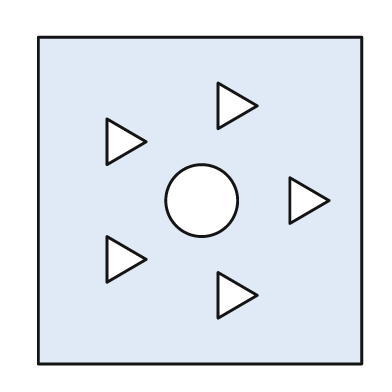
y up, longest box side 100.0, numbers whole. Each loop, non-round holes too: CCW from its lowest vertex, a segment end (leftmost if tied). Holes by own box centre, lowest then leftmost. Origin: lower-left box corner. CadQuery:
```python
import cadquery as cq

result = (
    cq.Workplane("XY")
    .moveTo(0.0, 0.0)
    .lineTo(99.0, 0.0)
    .lineTo(99.0, 100.0)
    .lineTo(0.0, 100.0)
    .close()
    .moveTo(55.0, 14.0)
    .lineTo(67.0, 21.0)
    .lineTo(55.0, 28.0)
    .close()
    .moveTo(21.0, 25.0)
    .lineTo(33.0, 32.0)
    .lineTo(21.0, 39.0)
    .close()
    .moveTo(50.0, 50.0)
    .circle(11.0)
    .moveTo(77.0, 43.0)
    .lineTo(89.0, 50.0)
    .lineTo(77.0, 57.0)
    .close()
    .moveTo(21.0, 61.0)
    .lineTo(33.0, 68.0)
    .lineTo(21.0, 75.0)
    .close()
    .moveTo(55.0, 72.0)
    .lineTo(67.0, 79.0)
    .lineTo(55.0, 86.0)
    .close()
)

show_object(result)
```